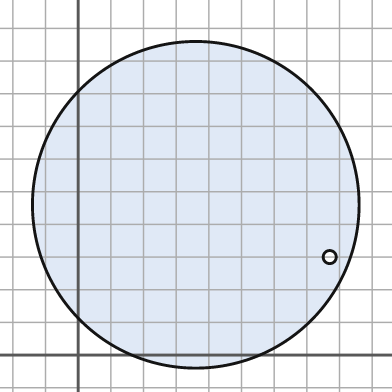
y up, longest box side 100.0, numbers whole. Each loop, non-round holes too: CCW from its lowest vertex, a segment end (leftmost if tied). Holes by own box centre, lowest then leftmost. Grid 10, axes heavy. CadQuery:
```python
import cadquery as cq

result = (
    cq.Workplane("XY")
    .moveTo(36.0, 46.0)
    .circle(50.0)
    .moveTo(77.0, 30.0)
    .circle(2.0)
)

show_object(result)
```